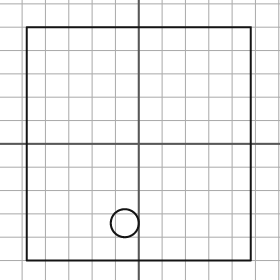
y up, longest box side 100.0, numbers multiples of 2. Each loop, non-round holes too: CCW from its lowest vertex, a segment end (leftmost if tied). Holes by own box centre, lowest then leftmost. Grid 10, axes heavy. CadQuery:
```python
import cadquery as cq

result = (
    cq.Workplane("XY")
    .moveTo(-48.0, -50.0)
    .lineTo(48.0, -50.0)
    .lineTo(48.0, 50.0)
    .lineTo(-48.0, 50.0)
    .close()
    .moveTo(-6.0, -34.0)
    .circle(6.0)
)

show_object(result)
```